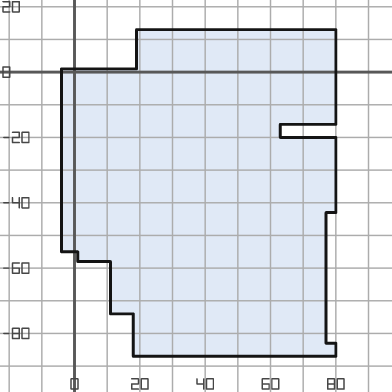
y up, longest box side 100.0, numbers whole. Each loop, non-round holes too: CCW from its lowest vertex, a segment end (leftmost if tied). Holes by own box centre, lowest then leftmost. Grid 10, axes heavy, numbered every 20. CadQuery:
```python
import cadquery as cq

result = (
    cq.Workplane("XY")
    .moveTo(18.0, -87.0)
    .lineTo(80.0, -87.0)
    .lineTo(80.0, -83.0)
    .lineTo(77.0, -83.0)
    .lineTo(77.0, -43.0)
    .lineTo(80.0, -43.0)
    .lineTo(80.0, -20.0)
    .lineTo(63.0, -20.0)
    .lineTo(63.0, -16.0)
    .lineTo(80.0, -16.0)
    .lineTo(80.0, 13.0)
    .lineTo(19.0, 13.0)
    .lineTo(19.0, 1.0)
    .lineTo(-4.0, 1.0)
    .lineTo(-4.0, -55.0)
    .lineTo(1.0, -55.0)
    .lineTo(1.0, -58.0)
    .lineTo(11.0, -58.0)
    .lineTo(11.0, -74.0)
    .lineTo(18.0, -74.0)
    .close()
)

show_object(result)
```